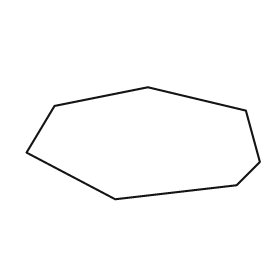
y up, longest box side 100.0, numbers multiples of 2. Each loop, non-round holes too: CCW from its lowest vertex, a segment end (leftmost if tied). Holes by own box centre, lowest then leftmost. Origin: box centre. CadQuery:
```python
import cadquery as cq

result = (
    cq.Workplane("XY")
    .moveTo(-12.0, -24.0)
    .lineTo(40.0, -18.0)
    .lineTo(50.0, -8.0)
    .lineTo(44.0, 14.0)
    .lineTo(2.0, 24.0)
    .lineTo(-38.0, 16.0)
    .lineTo(-50.0, -4.0)
    .close()
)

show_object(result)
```